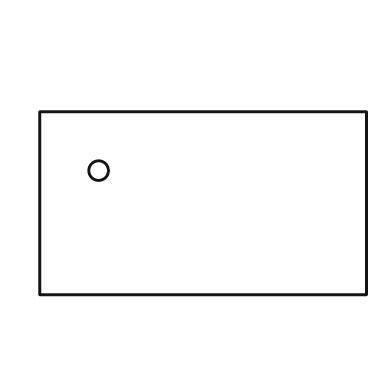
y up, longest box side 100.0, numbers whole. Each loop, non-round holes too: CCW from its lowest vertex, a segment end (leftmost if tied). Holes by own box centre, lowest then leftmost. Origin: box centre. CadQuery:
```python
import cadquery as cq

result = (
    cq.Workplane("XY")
    .moveTo(-50.0, -28.0)
    .lineTo(50.0, -28.0)
    .lineTo(50.0, 28.0)
    .lineTo(-50.0, 28.0)
    .close()
    .moveTo(-32.0, 10.0)
    .circle(3.0)
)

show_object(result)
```